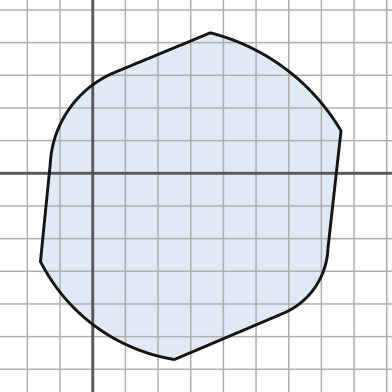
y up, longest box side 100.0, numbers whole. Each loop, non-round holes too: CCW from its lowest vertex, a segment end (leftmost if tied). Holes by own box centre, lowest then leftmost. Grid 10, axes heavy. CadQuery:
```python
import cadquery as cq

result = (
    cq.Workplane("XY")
    .moveTo(25.0, -57.0)
    .lineTo(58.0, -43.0)
    .threePointArc((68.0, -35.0), (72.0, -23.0))
    .lineTo(76.0, 13.0)
    .threePointArc((59.0, 32.0), (36.0, 43.0))
    .lineTo(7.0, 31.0)
    .threePointArc((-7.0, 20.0), (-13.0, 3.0))
    .lineTo(-16.0, -27.0)
    .threePointArc((1.0, -47.0), (25.0, -57.0))
    .close()
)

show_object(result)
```